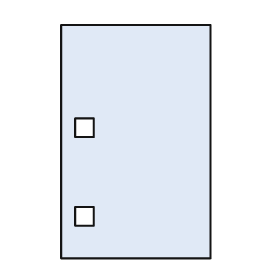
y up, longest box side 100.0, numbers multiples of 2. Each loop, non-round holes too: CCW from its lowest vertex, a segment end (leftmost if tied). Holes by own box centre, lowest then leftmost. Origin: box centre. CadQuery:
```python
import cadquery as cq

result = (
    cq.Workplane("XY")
    .moveTo(-32.0, -50.0)
    .lineTo(32.0, -50.0)
    .lineTo(32.0, 50.0)
    .lineTo(-32.0, 50.0)
    .close()
    .moveTo(-26.0, -36.0)
    .lineTo(-18.0, -36.0)
    .lineTo(-18.0, -28.0)
    .lineTo(-26.0, -28.0)
    .close()
    .moveTo(-26.0, 2.0)
    .lineTo(-18.0, 2.0)
    .lineTo(-18.0, 10.0)
    .lineTo(-26.0, 10.0)
    .close()
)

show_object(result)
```